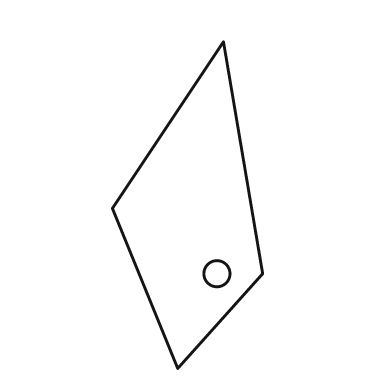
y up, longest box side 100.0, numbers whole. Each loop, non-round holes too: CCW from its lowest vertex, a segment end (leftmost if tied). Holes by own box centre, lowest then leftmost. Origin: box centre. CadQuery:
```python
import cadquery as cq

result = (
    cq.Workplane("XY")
    .moveTo(-3.0, -50.0)
    .lineTo(23.0, -21.0)
    .lineTo(11.0, 50.0)
    .lineTo(-23.0, -1.0)
    .close()
    .moveTo(9.0, -21.0)
    .circle(4.0)
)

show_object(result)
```